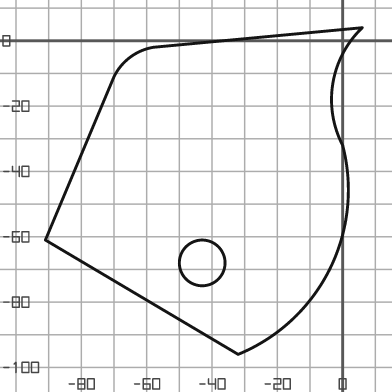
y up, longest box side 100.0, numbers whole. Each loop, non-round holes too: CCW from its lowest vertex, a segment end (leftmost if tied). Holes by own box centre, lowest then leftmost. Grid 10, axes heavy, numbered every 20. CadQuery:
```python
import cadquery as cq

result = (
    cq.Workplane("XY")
    .moveTo(-32.0, -96.0)
    .threePointArc((-4.0, -70.0), (0.0, -32.0))
    .threePointArc((-3.0, -13.0), (6.0, 4.0))
    .lineTo(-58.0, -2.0)
    .threePointArc((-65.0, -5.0), (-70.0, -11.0))
    .lineTo(-91.0, -61.0)
    .close()
    .moveTo(-43.0, -68.0)
    .circle(7.0)
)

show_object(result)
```